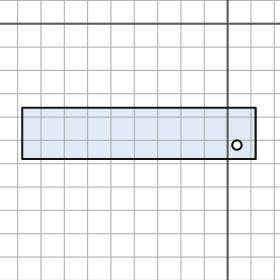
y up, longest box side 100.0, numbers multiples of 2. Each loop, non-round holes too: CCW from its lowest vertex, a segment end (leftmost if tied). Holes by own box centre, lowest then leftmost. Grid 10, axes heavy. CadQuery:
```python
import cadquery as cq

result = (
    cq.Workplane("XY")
    .moveTo(-88.0, -58.0)
    .lineTo(12.0, -58.0)
    .lineTo(12.0, -36.0)
    .lineTo(-88.0, -36.0)
    .close()
    .moveTo(4.0, -52.0)
    .circle(2.0)
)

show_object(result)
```